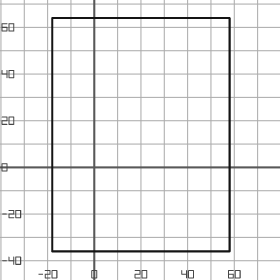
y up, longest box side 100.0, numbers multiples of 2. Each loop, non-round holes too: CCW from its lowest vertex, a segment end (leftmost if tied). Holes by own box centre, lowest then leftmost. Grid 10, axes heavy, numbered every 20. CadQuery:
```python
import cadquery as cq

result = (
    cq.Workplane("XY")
    .moveTo(-18.0, -36.0)
    .lineTo(58.0, -36.0)
    .lineTo(58.0, 64.0)
    .lineTo(-18.0, 64.0)
    .close()
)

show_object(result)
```